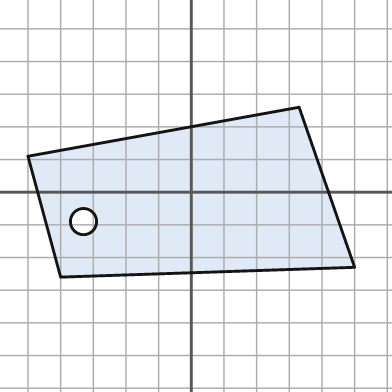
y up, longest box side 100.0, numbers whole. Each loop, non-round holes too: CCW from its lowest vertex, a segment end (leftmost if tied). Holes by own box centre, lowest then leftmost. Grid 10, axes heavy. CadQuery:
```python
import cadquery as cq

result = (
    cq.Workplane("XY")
    .moveTo(-40.0, -26.0)
    .lineTo(50.0, -23.0)
    .lineTo(33.0, 26.0)
    .lineTo(-50.0, 11.0)
    .close()
    .moveTo(-33.0, -9.0)
    .circle(4.0)
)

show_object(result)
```